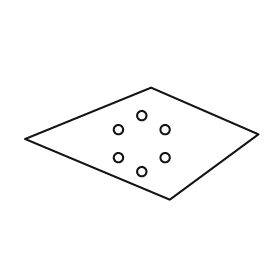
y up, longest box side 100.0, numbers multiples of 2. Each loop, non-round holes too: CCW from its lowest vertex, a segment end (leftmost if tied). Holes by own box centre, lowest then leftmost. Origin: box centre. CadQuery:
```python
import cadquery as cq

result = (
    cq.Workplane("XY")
    .moveTo(12.0, -24.0)
    .lineTo(50.0, 4.0)
    .lineTo(4.0, 24.0)
    .lineTo(-50.0, 2.0)
    .close()
    .moveTo(0.0, -12.0)
    .circle(2.0)
    .moveTo(-10.0, -6.0)
    .circle(2.0)
    .moveTo(10.0, -6.0)
    .circle(2.0)
    .moveTo(-10.0, 6.0)
    .circle(2.0)
    .moveTo(10.0, 6.0)
    .circle(2.0)
    .moveTo(0.0, 12.0)
    .circle(2.0)
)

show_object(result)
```